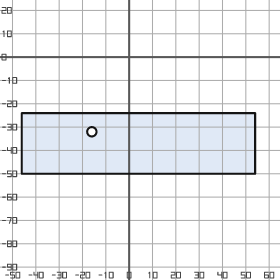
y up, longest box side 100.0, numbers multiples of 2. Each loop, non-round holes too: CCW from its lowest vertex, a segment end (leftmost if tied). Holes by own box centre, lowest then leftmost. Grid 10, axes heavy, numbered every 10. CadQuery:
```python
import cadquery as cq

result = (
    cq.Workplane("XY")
    .moveTo(-46.0, -50.0)
    .lineTo(54.0, -50.0)
    .lineTo(54.0, -24.0)
    .lineTo(-46.0, -24.0)
    .close()
    .moveTo(-16.0, -32.0)
    .circle(2.0)
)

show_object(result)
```